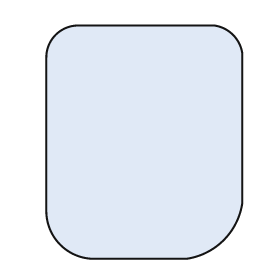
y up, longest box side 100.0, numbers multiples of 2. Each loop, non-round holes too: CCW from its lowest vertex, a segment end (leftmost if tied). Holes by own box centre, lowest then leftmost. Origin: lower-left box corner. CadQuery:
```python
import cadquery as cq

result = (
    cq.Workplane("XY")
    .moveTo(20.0, 0.0)
    .lineTo(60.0, 0.0)
    .threePointArc((76.0, 8.0), (84.0, 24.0))
    .lineTo(84.0, 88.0)
    .threePointArc((80.0, 96.0), (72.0, 100.0))
    .lineTo(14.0, 100.0)
    .threePointArc((4.0, 96.0), (0.0, 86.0))
    .lineTo(0.0, 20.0)
    .threePointArc((6.0, 6.0), (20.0, 0.0))
    .close()
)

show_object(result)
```